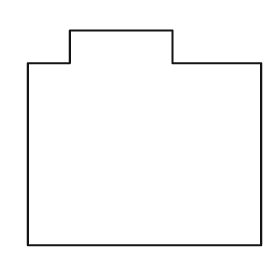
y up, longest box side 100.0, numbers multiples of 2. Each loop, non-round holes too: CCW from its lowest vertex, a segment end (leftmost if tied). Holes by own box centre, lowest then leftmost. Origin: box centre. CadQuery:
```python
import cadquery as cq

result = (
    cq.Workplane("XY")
    .moveTo(-50.0, -46.0)
    .lineTo(50.0, -46.0)
    .lineTo(50.0, 32.0)
    .lineTo(12.0, 32.0)
    .lineTo(12.0, 46.0)
    .lineTo(-32.0, 46.0)
    .lineTo(-32.0, 32.0)
    .lineTo(-50.0, 32.0)
    .close()
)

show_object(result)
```